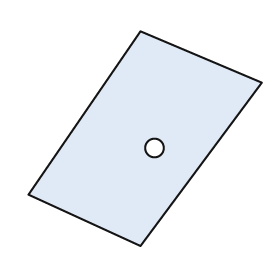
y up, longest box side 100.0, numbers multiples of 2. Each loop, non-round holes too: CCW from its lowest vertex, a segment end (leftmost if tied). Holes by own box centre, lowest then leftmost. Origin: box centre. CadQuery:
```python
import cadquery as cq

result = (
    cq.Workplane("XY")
    .moveTo(-2.0, -46.0)
    .lineTo(50.0, 24.0)
    .lineTo(-2.0, 46.0)
    .lineTo(-50.0, -24.0)
    .close()
    .moveTo(4.0, -4.0)
    .circle(4.0)
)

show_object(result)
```